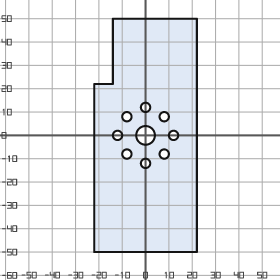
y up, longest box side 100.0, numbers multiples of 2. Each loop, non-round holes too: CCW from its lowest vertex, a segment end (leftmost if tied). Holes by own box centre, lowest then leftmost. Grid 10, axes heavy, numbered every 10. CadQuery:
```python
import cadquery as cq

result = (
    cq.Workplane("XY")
    .moveTo(-22.0, -50.0)
    .lineTo(22.0, -50.0)
    .lineTo(22.0, 50.0)
    .lineTo(-14.0, 50.0)
    .lineTo(-14.0, 22.0)
    .lineTo(-22.0, 22.0)
    .close()
    .moveTo(0.0, -12.0)
    .circle(2.0)
    .moveTo(-8.0, -8.0)
    .circle(2.0)
    .moveTo(8.0, -8.0)
    .circle(2.0)
    .moveTo(-12.0, 0.0)
    .circle(2.0)
    .moveTo(0.0, 0.0)
    .circle(4.0)
    .moveTo(12.0, 0.0)
    .circle(2.0)
    .moveTo(-8.0, 8.0)
    .circle(2.0)
    .moveTo(8.0, 8.0)
    .circle(2.0)
    .moveTo(0.0, 12.0)
    .circle(2.0)
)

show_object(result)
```